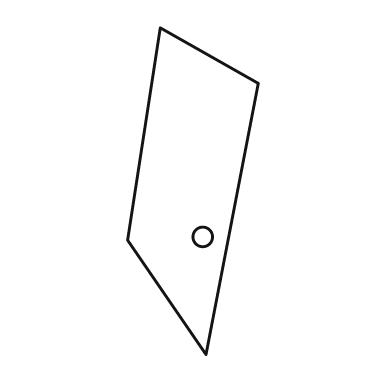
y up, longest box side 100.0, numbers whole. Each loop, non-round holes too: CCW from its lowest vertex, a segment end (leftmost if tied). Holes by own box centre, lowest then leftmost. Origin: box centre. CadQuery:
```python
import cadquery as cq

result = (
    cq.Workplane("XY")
    .moveTo(4.0, -50.0)
    .lineTo(20.0, 33.0)
    .lineTo(-10.0, 50.0)
    .lineTo(-20.0, -15.0)
    .close()
    .moveTo(3.0, -14.0)
    .circle(3.0)
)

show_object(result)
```